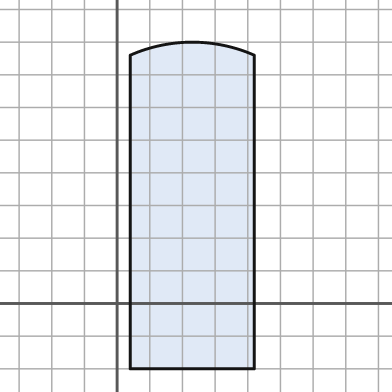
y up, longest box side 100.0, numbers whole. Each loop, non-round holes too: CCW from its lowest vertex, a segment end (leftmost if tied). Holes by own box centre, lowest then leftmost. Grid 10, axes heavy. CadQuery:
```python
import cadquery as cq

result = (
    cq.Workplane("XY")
    .moveTo(4.0, -20.0)
    .lineTo(42.0, -20.0)
    .lineTo(42.0, 76.0)
    .threePointArc((23.0, 80.0), (4.0, 76.0))
    .close()
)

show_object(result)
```